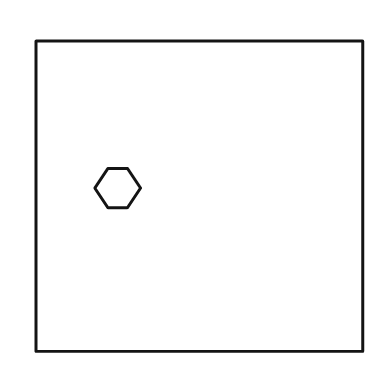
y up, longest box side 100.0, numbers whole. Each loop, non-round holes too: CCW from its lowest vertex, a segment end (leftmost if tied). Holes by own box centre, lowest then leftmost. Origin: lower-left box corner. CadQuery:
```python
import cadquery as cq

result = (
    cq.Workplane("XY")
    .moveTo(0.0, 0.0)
    .lineTo(100.0, 0.0)
    .lineTo(100.0, 95.0)
    .lineTo(0.0, 95.0)
    .close()
    .moveTo(22.0, 44.0)
    .lineTo(28.0, 44.0)
    .lineTo(32.0, 50.0)
    .lineTo(28.0, 56.0)
    .lineTo(22.0, 56.0)
    .lineTo(18.0, 50.0)
    .close()
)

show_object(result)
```